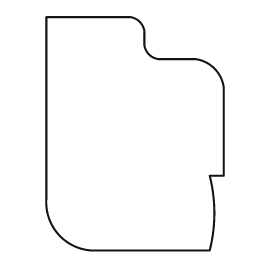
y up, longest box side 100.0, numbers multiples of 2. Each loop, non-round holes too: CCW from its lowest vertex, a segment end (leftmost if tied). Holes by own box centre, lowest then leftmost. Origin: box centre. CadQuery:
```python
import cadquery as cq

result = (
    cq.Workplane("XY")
    .moveTo(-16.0, -50.0)
    .lineTo(32.0, -50.0)
    .threePointArc((34.0, -34.0), (32.0, -18.0))
    .lineTo(38.0, -18.0)
    .lineTo(38.0, 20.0)
    .threePointArc((34.0, 28.0), (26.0, 32.0))
    .lineTo(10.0, 32.0)
    .threePointArc((6.0, 34.0), (4.0, 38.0))
    .lineTo(4.0, 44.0)
    .threePointArc((2.0, 48.0), (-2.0, 50.0))
    .lineTo(-38.0, 50.0)
    .lineTo(-38.0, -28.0)
    .threePointArc((-32.0, -44.0), (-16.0, -50.0))
    .close()
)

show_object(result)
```